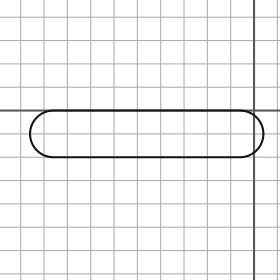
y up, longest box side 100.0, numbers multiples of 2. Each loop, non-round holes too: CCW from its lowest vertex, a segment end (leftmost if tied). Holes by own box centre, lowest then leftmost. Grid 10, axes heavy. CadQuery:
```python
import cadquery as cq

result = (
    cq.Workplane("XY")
    .moveTo(-86.0, -20.0)
    .lineTo(-6.0, -20.0)
    .threePointArc((4.0, -10.0), (-6.0, 0.0))
    .lineTo(-86.0, 0.0)
    .threePointArc((-96.0, -10.0), (-86.0, -20.0))
    .close()
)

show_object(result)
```